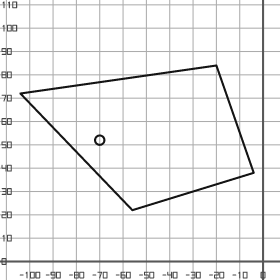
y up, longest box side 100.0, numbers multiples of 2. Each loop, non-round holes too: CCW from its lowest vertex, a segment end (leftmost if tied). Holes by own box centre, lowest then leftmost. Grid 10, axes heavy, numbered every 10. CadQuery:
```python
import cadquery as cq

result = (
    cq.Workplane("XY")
    .moveTo(-56.0, 22.0)
    .lineTo(-4.0, 38.0)
    .lineTo(-20.0, 84.0)
    .lineTo(-104.0, 72.0)
    .close()
    .moveTo(-70.0, 52.0)
    .circle(2.0)
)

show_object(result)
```